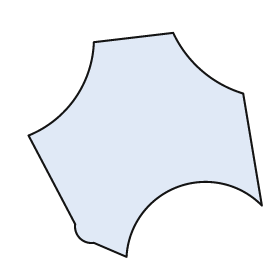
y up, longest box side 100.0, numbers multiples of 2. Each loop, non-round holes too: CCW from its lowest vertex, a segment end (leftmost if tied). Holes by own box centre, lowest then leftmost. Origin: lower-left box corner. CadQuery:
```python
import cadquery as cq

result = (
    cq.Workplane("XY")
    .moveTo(42.0, 0.0)
    .threePointArc((64.0, 30.0), (100.0, 22.0))
    .lineTo(92.0, 70.0)
    .threePointArc((74.0, 80.0), (62.0, 96.0))
    .lineTo(28.0, 92.0)
    .threePointArc((20.0, 68.0), (0.0, 52.0))
    .lineTo(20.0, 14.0)
    .threePointArc((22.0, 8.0), (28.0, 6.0))
    .close()
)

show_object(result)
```